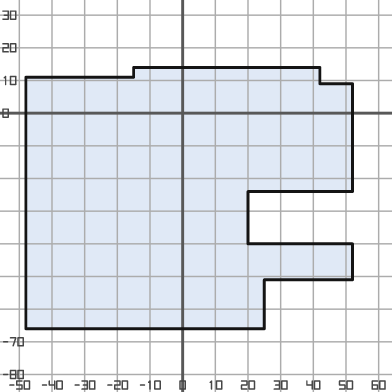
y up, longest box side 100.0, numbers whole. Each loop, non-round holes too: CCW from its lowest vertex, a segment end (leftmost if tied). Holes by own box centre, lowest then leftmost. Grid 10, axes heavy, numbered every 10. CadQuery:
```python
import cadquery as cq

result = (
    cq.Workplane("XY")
    .moveTo(-48.0, -66.0)
    .lineTo(25.0, -66.0)
    .lineTo(25.0, -51.0)
    .lineTo(52.0, -51.0)
    .lineTo(52.0, -40.0)
    .lineTo(20.0, -40.0)
    .lineTo(20.0, -24.0)
    .lineTo(52.0, -24.0)
    .lineTo(52.0, 9.0)
    .lineTo(42.0, 9.0)
    .lineTo(42.0, 14.0)
    .lineTo(-15.0, 14.0)
    .lineTo(-15.0, 11.0)
    .lineTo(-48.0, 11.0)
    .close()
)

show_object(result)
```